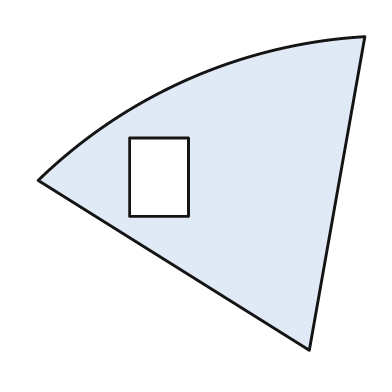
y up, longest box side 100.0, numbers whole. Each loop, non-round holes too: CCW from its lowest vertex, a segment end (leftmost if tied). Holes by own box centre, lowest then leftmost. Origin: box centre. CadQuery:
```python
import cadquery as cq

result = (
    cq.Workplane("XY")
    .moveTo(33.0, -48.0)
    .lineTo(50.0, 48.0)
    .threePointArc((-4.0, 35.0), (-50.0, 4.0))
    .close()
    .moveTo(-22.0, -7.0)
    .lineTo(-4.0, -7.0)
    .lineTo(-4.0, 17.0)
    .lineTo(-22.0, 17.0)
    .close()
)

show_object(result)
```